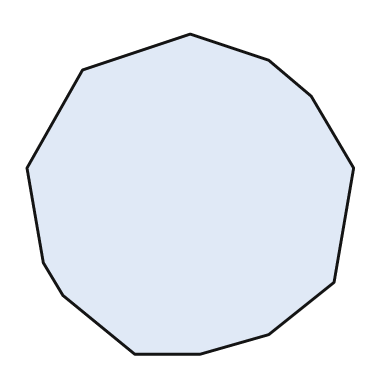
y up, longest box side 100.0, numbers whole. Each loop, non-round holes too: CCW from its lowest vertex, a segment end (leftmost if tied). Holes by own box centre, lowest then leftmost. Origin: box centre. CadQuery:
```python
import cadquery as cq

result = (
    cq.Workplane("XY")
    .moveTo(-17.0, -49.0)
    .lineTo(3.0, -49.0)
    .lineTo(24.0, -43.0)
    .lineTo(44.0, -27.0)
    .lineTo(50.0, 8.0)
    .lineTo(37.0, 30.0)
    .lineTo(24.0, 41.0)
    .lineTo(0.0, 49.0)
    .lineTo(-33.0, 38.0)
    .lineTo(-50.0, 8.0)
    .lineTo(-45.0, -21.0)
    .lineTo(-39.0, -31.0)
    .close()
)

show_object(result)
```